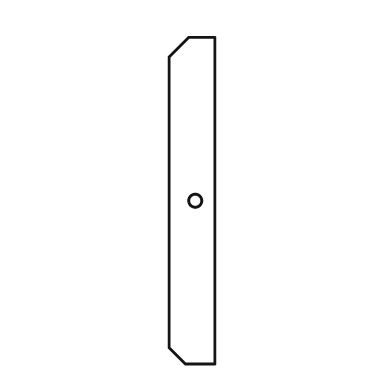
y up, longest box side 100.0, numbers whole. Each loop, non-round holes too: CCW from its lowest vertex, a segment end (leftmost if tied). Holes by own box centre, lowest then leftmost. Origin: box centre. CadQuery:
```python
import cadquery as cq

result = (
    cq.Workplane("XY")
    .moveTo(-2.0, -50.0)
    .lineTo(7.0, -50.0)
    .lineTo(7.0, 50.0)
    .lineTo(-1.0, 50.0)
    .lineTo(-7.0, 44.0)
    .lineTo(-7.0, -45.0)
    .close()
    .moveTo(1.0, 0.0)
    .circle(2.0)
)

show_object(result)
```